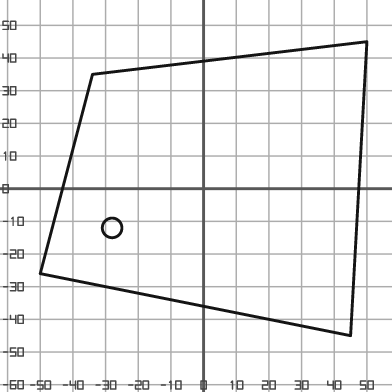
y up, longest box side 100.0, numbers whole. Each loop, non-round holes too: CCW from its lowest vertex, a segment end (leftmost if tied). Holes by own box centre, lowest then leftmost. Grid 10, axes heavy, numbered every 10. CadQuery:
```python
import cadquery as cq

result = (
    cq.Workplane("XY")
    .moveTo(45.0, -45.0)
    .lineTo(50.0, 45.0)
    .lineTo(-34.0, 35.0)
    .lineTo(-50.0, -26.0)
    .close()
    .moveTo(-28.0, -12.0)
    .circle(3.0)
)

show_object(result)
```